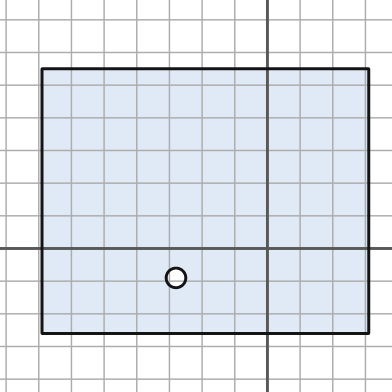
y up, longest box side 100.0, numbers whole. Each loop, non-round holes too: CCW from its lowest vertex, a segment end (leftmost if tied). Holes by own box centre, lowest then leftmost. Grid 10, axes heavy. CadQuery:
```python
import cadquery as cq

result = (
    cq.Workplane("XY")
    .moveTo(-69.0, -26.0)
    .lineTo(31.0, -26.0)
    .lineTo(31.0, 55.0)
    .lineTo(-69.0, 55.0)
    .close()
    .moveTo(-28.0, -9.0)
    .circle(3.0)
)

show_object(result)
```